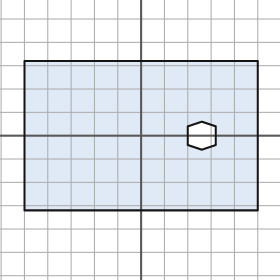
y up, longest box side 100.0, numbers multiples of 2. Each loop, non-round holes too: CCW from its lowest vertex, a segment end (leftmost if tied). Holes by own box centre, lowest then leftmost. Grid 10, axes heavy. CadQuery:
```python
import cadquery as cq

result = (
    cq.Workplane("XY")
    .moveTo(-50.0, -32.0)
    .lineTo(50.0, -32.0)
    .lineTo(50.0, 32.0)
    .lineTo(-50.0, 32.0)
    .close()
    .moveTo(26.0, -6.0)
    .lineTo(32.0, -4.0)
    .lineTo(32.0, 4.0)
    .lineTo(26.0, 6.0)
    .lineTo(20.0, 4.0)
    .lineTo(20.0, -4.0)
    .close()
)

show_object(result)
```